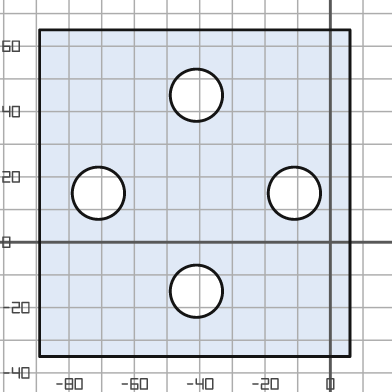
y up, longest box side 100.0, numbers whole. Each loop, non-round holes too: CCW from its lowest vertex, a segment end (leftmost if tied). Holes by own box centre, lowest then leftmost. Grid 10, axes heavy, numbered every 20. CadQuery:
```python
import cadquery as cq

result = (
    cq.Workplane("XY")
    .moveTo(-89.0, -35.0)
    .lineTo(6.0, -35.0)
    .lineTo(6.0, 65.0)
    .lineTo(-89.0, 65.0)
    .close()
    .moveTo(-41.0, -15.0)
    .circle(8.0)
    .moveTo(-71.0, 15.0)
    .circle(8.0)
    .moveTo(-11.0, 15.0)
    .circle(8.0)
    .moveTo(-41.0, 45.0)
    .circle(8.0)
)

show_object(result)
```